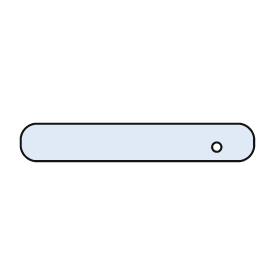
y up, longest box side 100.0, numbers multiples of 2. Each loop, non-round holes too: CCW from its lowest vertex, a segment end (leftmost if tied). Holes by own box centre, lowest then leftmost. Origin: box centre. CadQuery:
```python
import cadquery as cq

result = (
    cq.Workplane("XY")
    .moveTo(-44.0, -8.0)
    .lineTo(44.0, -8.0)
    .threePointArc((48.0, -6.0), (50.0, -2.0))
    .lineTo(50.0, 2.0)
    .threePointArc((48.0, 6.0), (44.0, 8.0))
    .lineTo(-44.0, 8.0)
    .threePointArc((-48.0, 6.0), (-50.0, 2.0))
    .lineTo(-50.0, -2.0)
    .threePointArc((-48.0, -6.0), (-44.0, -8.0))
    .close()
    .moveTo(34.0, -2.0)
    .circle(2.0)
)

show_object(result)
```